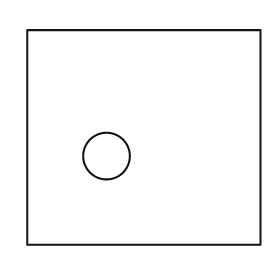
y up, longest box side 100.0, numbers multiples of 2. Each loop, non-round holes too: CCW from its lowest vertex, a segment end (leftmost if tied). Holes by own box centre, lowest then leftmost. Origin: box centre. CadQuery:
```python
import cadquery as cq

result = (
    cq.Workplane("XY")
    .moveTo(-50.0, -46.0)
    .lineTo(50.0, -46.0)
    .lineTo(50.0, 46.0)
    .lineTo(-50.0, 46.0)
    .close()
    .moveTo(-16.0, -8.0)
    .circle(10.0)
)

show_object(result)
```